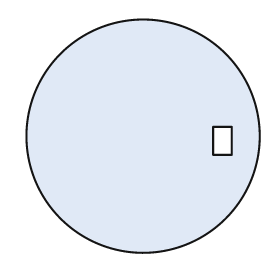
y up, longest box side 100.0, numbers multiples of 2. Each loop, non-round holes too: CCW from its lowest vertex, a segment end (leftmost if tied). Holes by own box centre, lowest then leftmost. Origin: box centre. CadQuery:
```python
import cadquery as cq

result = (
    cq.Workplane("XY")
    .moveTo(0.0, 0.0)
    .circle(50.0)
    .moveTo(30.0, -8.0)
    .lineTo(38.0, -8.0)
    .lineTo(38.0, 4.0)
    .lineTo(30.0, 4.0)
    .close()
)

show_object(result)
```